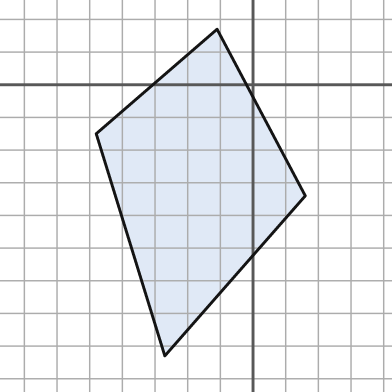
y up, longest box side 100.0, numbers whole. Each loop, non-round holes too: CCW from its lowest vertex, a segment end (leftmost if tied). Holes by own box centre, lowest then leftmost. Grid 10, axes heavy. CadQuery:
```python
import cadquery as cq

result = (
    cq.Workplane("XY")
    .moveTo(-27.0, -83.0)
    .lineTo(16.0, -34.0)
    .lineTo(-11.0, 17.0)
    .lineTo(-48.0, -15.0)
    .close()
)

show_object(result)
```